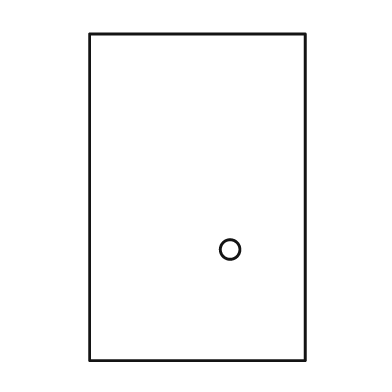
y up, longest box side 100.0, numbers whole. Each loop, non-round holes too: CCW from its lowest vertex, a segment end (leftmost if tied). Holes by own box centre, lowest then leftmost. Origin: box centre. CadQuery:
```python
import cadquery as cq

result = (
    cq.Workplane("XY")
    .moveTo(-33.0, -50.0)
    .lineTo(33.0, -50.0)
    .lineTo(33.0, 50.0)
    .lineTo(-33.0, 50.0)
    .close()
    .moveTo(10.0, -16.0)
    .circle(3.0)
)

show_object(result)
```